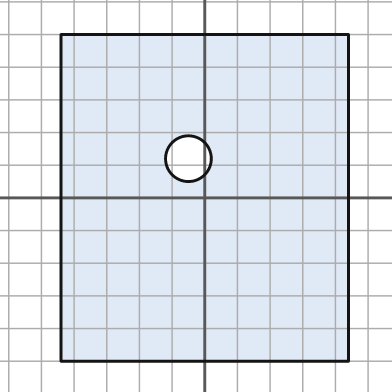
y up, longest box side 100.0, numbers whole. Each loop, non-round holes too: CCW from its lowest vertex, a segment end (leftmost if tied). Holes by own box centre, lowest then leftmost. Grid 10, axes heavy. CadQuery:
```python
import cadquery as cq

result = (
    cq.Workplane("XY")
    .moveTo(-44.0, -50.0)
    .lineTo(44.0, -50.0)
    .lineTo(44.0, 50.0)
    .lineTo(-44.0, 50.0)
    .close()
    .moveTo(-5.0, 12.0)
    .circle(7.0)
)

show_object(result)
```